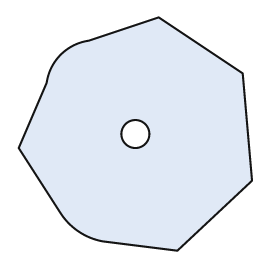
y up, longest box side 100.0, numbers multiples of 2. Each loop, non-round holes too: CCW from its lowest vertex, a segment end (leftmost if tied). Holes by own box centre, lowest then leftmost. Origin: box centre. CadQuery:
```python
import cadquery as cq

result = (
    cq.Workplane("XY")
    .moveTo(18.0, -50.0)
    .lineTo(50.0, -20.0)
    .lineTo(46.0, 26.0)
    .lineTo(10.0, 50.0)
    .lineTo(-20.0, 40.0)
    .threePointArc((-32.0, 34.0), (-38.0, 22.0))
    .lineTo(-50.0, -6.0)
    .lineTo(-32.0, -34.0)
    .threePointArc((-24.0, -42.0), (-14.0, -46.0))
    .close()
    .moveTo(0.0, 0.0)
    .circle(6.0)
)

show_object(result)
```